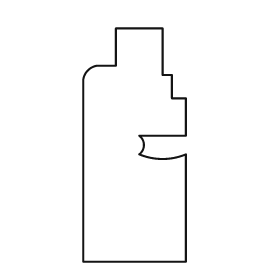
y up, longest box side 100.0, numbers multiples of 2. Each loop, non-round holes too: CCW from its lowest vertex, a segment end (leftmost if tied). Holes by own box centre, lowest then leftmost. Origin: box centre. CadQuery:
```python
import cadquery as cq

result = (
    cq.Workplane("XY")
    .moveTo(-22.0, -50.0)
    .lineTo(22.0, -50.0)
    .lineTo(22.0, -4.0)
    .threePointArc((12.0, -6.0), (2.0, -4.0))
    .threePointArc((4.0, 0.0), (2.0, 4.0))
    .lineTo(22.0, 4.0)
    .lineTo(22.0, 20.0)
    .lineTo(16.0, 20.0)
    .lineTo(16.0, 30.0)
    .lineTo(12.0, 30.0)
    .lineTo(12.0, 50.0)
    .lineTo(-8.0, 50.0)
    .lineTo(-8.0, 34.0)
    .lineTo(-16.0, 34.0)
    .threePointArc((-20.0, 32.0), (-22.0, 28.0))
    .close()
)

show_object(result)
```